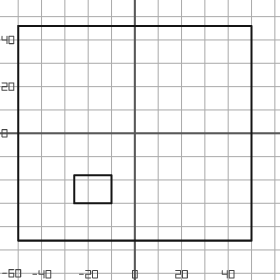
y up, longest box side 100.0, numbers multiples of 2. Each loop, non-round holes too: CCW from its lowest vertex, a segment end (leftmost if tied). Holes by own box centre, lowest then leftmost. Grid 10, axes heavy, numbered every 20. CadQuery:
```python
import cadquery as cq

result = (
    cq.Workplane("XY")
    .moveTo(-50.0, -46.0)
    .lineTo(50.0, -46.0)
    .lineTo(50.0, 46.0)
    .lineTo(-50.0, 46.0)
    .close()
    .moveTo(-26.0, -30.0)
    .lineTo(-10.0, -30.0)
    .lineTo(-10.0, -18.0)
    .lineTo(-26.0, -18.0)
    .close()
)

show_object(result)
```